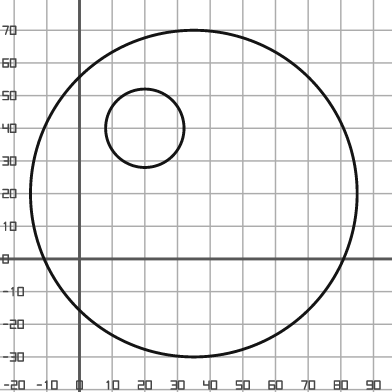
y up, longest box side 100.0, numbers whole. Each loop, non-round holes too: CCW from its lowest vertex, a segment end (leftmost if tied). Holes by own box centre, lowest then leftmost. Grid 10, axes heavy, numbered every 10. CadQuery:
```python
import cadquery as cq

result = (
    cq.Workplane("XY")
    .moveTo(35.0, 20.0)
    .circle(50.0)
    .moveTo(20.0, 40.0)
    .circle(12.0)
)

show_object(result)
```